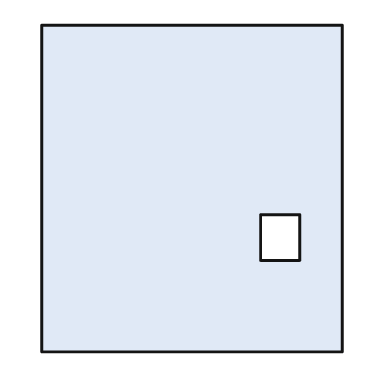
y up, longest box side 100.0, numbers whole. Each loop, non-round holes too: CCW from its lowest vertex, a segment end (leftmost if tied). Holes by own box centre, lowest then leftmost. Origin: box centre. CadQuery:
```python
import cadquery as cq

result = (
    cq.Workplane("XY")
    .moveTo(-46.0, -50.0)
    .lineTo(46.0, -50.0)
    .lineTo(46.0, 50.0)
    .lineTo(-46.0, 50.0)
    .close()
    .moveTo(21.0, -22.0)
    .lineTo(33.0, -22.0)
    .lineTo(33.0, -8.0)
    .lineTo(21.0, -8.0)
    .close()
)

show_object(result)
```